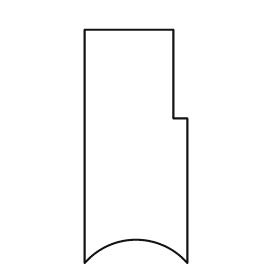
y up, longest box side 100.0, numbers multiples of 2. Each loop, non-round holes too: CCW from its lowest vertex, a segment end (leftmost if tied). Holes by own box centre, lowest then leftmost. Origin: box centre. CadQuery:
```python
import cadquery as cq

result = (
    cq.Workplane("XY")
    .moveTo(-22.0, -50.0)
    .threePointArc((0.0, -40.0), (22.0, -50.0))
    .lineTo(22.0, 12.0)
    .lineTo(16.0, 12.0)
    .lineTo(16.0, 50.0)
    .lineTo(-22.0, 50.0)
    .close()
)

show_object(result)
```